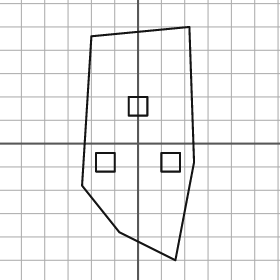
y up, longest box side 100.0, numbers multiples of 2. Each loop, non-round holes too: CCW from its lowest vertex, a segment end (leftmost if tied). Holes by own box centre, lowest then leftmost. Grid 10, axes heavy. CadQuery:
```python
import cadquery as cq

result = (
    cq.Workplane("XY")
    .moveTo(16.0, -50.0)
    .lineTo(24.0, -8.0)
    .lineTo(22.0, 50.0)
    .lineTo(-20.0, 46.0)
    .lineTo(-24.0, -18.0)
    .lineTo(-8.0, -38.0)
    .close()
    .moveTo(-18.0, -12.0)
    .lineTo(-10.0, -12.0)
    .lineTo(-10.0, -4.0)
    .lineTo(-18.0, -4.0)
    .close()
    .moveTo(10.0, -12.0)
    .lineTo(18.0, -12.0)
    .lineTo(18.0, -4.0)
    .lineTo(10.0, -4.0)
    .close()
    .moveTo(-4.0, 12.0)
    .lineTo(4.0, 12.0)
    .lineTo(4.0, 20.0)
    .lineTo(-4.0, 20.0)
    .close()
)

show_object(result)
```